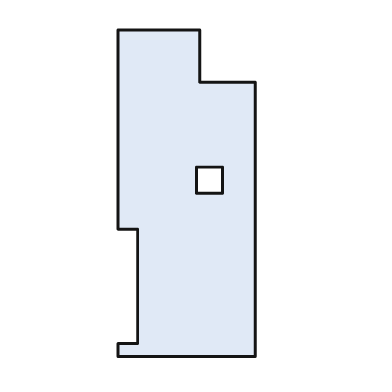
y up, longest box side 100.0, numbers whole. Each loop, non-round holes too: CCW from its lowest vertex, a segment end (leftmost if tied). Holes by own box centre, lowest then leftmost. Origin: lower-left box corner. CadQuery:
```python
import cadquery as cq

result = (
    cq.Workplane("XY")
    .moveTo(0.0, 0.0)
    .lineTo(42.0, 0.0)
    .lineTo(42.0, 84.0)
    .lineTo(25.0, 84.0)
    .lineTo(25.0, 100.0)
    .lineTo(0.0, 100.0)
    .lineTo(0.0, 39.0)
    .lineTo(6.0, 39.0)
    .lineTo(6.0, 4.0)
    .lineTo(0.0, 4.0)
    .close()
    .moveTo(24.0, 50.0)
    .lineTo(32.0, 50.0)
    .lineTo(32.0, 58.0)
    .lineTo(24.0, 58.0)
    .close()
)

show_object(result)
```